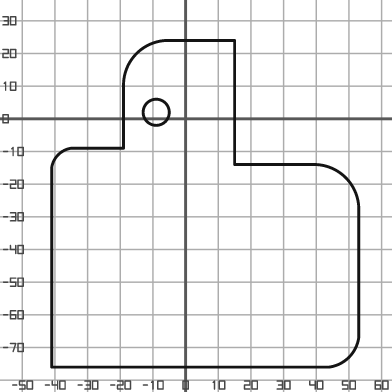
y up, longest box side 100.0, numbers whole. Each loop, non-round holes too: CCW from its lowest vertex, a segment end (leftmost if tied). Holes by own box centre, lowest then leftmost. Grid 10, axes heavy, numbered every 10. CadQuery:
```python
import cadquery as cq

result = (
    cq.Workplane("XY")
    .moveTo(-41.0, -76.0)
    .lineTo(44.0, -76.0)
    .threePointArc((50.0, -73.0), (53.0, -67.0))
    .lineTo(53.0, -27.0)
    .threePointArc((49.0, -18.0), (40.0, -14.0))
    .lineTo(15.0, -14.0)
    .lineTo(15.0, 24.0)
    .lineTo(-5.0, 24.0)
    .threePointArc((-15.0, 20.0), (-19.0, 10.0))
    .lineTo(-19.0, -9.0)
    .lineTo(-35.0, -9.0)
    .threePointArc((-39.0, -11.0), (-41.0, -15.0))
    .close()
    .moveTo(-9.0, 2.0)
    .circle(4.0)
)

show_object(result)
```